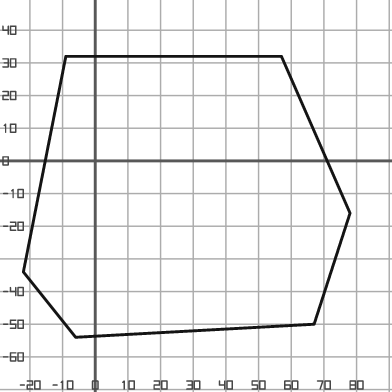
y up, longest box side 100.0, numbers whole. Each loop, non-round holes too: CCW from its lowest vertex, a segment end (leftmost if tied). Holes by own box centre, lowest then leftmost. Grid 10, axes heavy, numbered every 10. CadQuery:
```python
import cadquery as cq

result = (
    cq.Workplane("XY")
    .moveTo(-6.0, -54.0)
    .lineTo(67.0, -50.0)
    .lineTo(78.0, -16.0)
    .lineTo(57.0, 32.0)
    .lineTo(-9.0, 32.0)
    .lineTo(-22.0, -34.0)
    .close()
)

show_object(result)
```